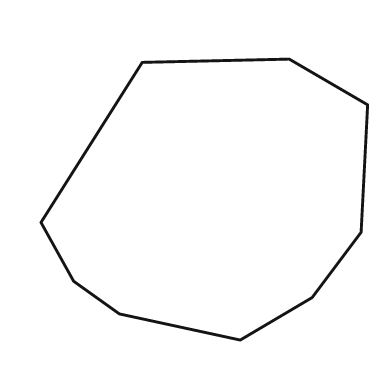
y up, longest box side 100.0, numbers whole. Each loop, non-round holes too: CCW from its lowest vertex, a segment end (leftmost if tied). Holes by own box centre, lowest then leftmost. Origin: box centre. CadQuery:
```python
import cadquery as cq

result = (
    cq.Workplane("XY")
    .moveTo(11.0, -43.0)
    .lineTo(33.0, -30.0)
    .lineTo(48.0, -10.0)
    .lineTo(50.0, 29.0)
    .lineTo(26.0, 43.0)
    .lineTo(-19.0, 42.0)
    .lineTo(-50.0, -7.0)
    .lineTo(-40.0, -25.0)
    .lineTo(-26.0, -35.0)
    .close()
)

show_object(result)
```